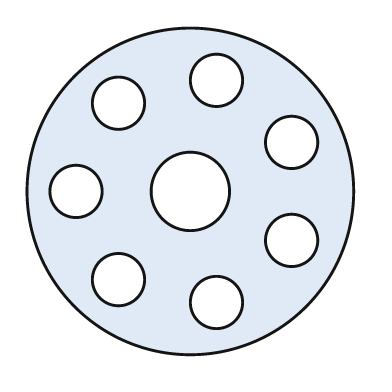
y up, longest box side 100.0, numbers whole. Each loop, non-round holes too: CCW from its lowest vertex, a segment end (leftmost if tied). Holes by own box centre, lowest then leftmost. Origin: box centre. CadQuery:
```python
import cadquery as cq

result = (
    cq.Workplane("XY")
    .moveTo(0.0, 0.0)
    .circle(50.0)
    .moveTo(8.0, -34.0)
    .circle(8.0)
    .moveTo(-22.0, -27.0)
    .circle(8.0)
    .moveTo(31.0, -15.0)
    .circle(8.0)
    .moveTo(-35.0, 0.0)
    .circle(8.0)
    .moveTo(0.0, 0.0)
    .circle(12.0)
    .moveTo(31.0, 15.0)
    .circle(8.0)
    .moveTo(-22.0, 27.0)
    .circle(8.0)
    .moveTo(8.0, 34.0)
    .circle(8.0)
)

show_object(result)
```